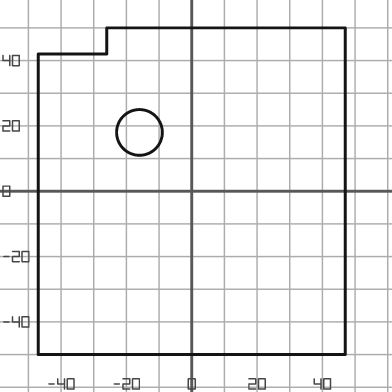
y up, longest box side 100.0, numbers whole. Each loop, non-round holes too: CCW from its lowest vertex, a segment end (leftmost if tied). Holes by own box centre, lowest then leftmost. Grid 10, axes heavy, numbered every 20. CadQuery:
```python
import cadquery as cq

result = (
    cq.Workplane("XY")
    .moveTo(-47.0, -50.0)
    .lineTo(47.0, -50.0)
    .lineTo(47.0, 50.0)
    .lineTo(-26.0, 50.0)
    .lineTo(-26.0, 42.0)
    .lineTo(-47.0, 42.0)
    .close()
    .moveTo(-16.0, 18.0)
    .circle(7.0)
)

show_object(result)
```